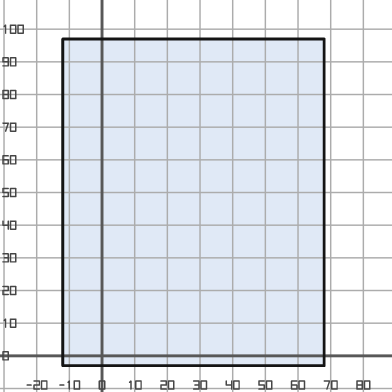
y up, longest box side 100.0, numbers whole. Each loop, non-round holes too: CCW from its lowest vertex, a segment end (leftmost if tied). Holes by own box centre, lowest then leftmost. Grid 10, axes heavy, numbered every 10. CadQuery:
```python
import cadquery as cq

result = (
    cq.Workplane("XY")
    .moveTo(-12.0, -3.0)
    .lineTo(68.0, -3.0)
    .lineTo(68.0, 97.0)
    .lineTo(-12.0, 97.0)
    .close()
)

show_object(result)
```